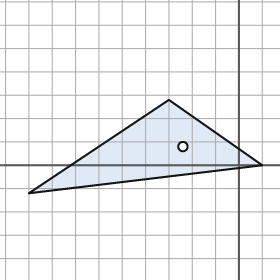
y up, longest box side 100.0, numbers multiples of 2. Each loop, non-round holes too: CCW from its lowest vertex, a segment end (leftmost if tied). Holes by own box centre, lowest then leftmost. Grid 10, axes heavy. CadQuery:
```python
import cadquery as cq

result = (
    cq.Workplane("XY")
    .moveTo(-90.0, -12.0)
    .lineTo(10.0, 0.0)
    .lineTo(-30.0, 28.0)
    .close()
    .moveTo(-24.0, 8.0)
    .circle(2.0)
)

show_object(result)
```